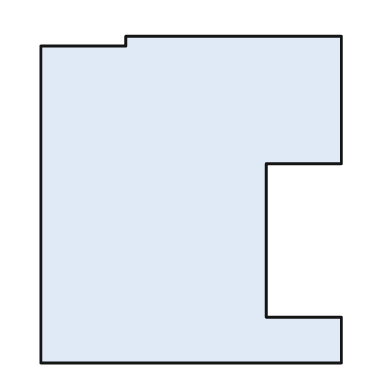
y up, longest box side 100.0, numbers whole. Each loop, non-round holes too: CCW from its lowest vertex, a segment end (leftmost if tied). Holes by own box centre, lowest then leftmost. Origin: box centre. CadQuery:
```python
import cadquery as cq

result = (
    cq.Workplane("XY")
    .moveTo(-46.0, -50.0)
    .lineTo(46.0, -50.0)
    .lineTo(46.0, -36.0)
    .lineTo(23.0, -36.0)
    .lineTo(23.0, 11.0)
    .lineTo(46.0, 11.0)
    .lineTo(46.0, 50.0)
    .lineTo(-20.0, 50.0)
    .lineTo(-20.0, 47.0)
    .lineTo(-46.0, 47.0)
    .close()
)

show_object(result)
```